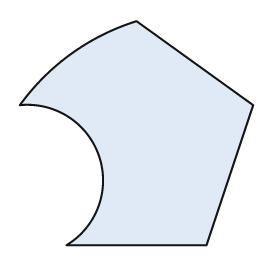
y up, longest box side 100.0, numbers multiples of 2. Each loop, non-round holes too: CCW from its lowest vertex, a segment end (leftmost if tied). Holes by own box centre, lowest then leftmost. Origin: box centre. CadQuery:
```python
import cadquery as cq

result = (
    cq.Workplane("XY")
    .moveTo(-30.0, -48.0)
    .lineTo(30.0, -48.0)
    .lineTo(50.0, 12.0)
    .lineTo(0.0, 48.0)
    .threePointArc((-28.0, 34.0), (-50.0, 12.0))
    .threePointArc((-16.0, -10.0), (-30.0, -48.0))
    .close()
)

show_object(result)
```